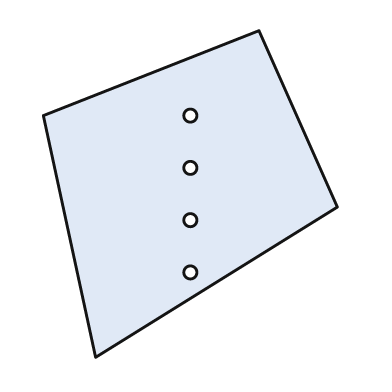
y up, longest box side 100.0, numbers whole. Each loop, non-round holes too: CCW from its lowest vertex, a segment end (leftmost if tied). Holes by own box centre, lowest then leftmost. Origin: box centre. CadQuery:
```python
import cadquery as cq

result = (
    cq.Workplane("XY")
    .moveTo(-29.0, -50.0)
    .lineTo(45.0, -4.0)
    .lineTo(21.0, 50.0)
    .lineTo(-45.0, 24.0)
    .close()
    .moveTo(0.0, -24.0)
    .circle(2.0)
    .moveTo(0.0, -8.0)
    .circle(2.0)
    .moveTo(0.0, 8.0)
    .circle(2.0)
    .moveTo(0.0, 24.0)
    .circle(2.0)
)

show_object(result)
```